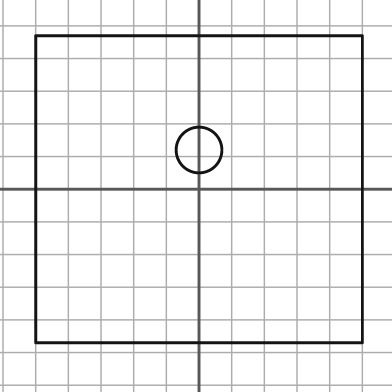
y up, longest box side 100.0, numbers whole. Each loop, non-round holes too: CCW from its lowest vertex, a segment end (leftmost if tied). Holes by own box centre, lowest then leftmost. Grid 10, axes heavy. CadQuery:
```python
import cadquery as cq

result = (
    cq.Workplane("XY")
    .moveTo(-50.0, -47.0)
    .lineTo(50.0, -47.0)
    .lineTo(50.0, 47.0)
    .lineTo(-50.0, 47.0)
    .close()
    .moveTo(0.0, 12.0)
    .circle(7.0)
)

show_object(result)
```